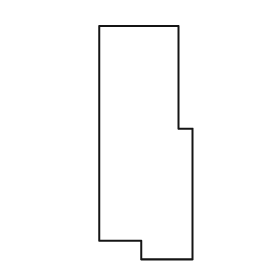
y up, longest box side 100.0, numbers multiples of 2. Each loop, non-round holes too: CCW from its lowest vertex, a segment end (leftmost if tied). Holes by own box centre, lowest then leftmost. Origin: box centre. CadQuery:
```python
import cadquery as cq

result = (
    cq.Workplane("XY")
    .moveTo(-2.0, -50.0)
    .lineTo(20.0, -50.0)
    .lineTo(20.0, 6.0)
    .lineTo(14.0, 6.0)
    .lineTo(14.0, 50.0)
    .lineTo(-20.0, 50.0)
    .lineTo(-20.0, -42.0)
    .lineTo(-2.0, -42.0)
    .close()
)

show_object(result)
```